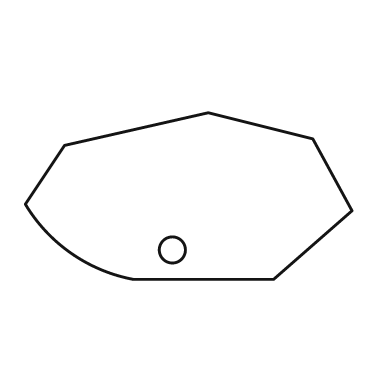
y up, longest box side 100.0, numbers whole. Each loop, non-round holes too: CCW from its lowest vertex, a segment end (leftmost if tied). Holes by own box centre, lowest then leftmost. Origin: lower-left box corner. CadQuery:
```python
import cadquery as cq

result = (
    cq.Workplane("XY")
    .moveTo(33.0, 0.0)
    .lineTo(76.0, 0.0)
    .lineTo(100.0, 21.0)
    .lineTo(88.0, 43.0)
    .lineTo(56.0, 51.0)
    .lineTo(12.0, 41.0)
    .lineTo(0.0, 23.0)
    .threePointArc((14.0, 8.0), (33.0, 0.0))
    .close()
    .moveTo(45.0, 9.0)
    .circle(4.0)
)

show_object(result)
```